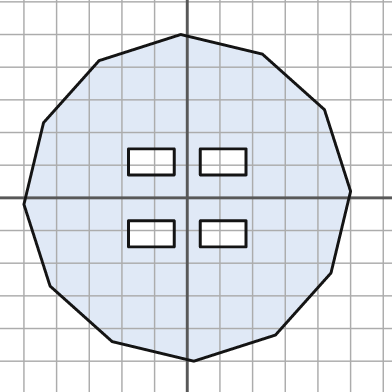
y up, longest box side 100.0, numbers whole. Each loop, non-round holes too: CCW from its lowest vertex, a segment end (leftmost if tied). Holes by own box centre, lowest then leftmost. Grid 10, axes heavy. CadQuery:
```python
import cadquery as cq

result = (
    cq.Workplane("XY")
    .moveTo(2.0, -50.0)
    .lineTo(27.0, -42.0)
    .lineTo(44.0, -23.0)
    .lineTo(50.0, 2.0)
    .lineTo(42.0, 27.0)
    .lineTo(23.0, 44.0)
    .lineTo(-2.0, 50.0)
    .lineTo(-27.0, 42.0)
    .lineTo(-44.0, 23.0)
    .lineTo(-50.0, -2.0)
    .lineTo(-42.0, -27.0)
    .lineTo(-23.0, -44.0)
    .close()
    .moveTo(-18.0, -15.0)
    .lineTo(-4.0, -15.0)
    .lineTo(-4.0, -7.0)
    .lineTo(-18.0, -7.0)
    .close()
    .moveTo(4.0, -15.0)
    .lineTo(18.0, -15.0)
    .lineTo(18.0, -7.0)
    .lineTo(4.0, -7.0)
    .close()
    .moveTo(-18.0, 7.0)
    .lineTo(-4.0, 7.0)
    .lineTo(-4.0, 15.0)
    .lineTo(-18.0, 15.0)
    .close()
    .moveTo(4.0, 7.0)
    .lineTo(18.0, 7.0)
    .lineTo(18.0, 15.0)
    .lineTo(4.0, 15.0)
    .close()
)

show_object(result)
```